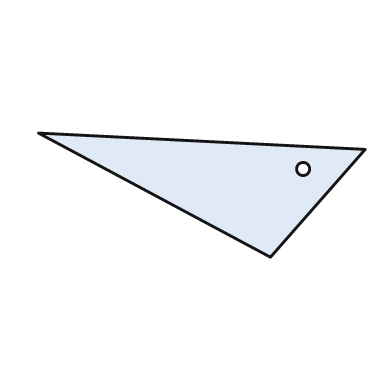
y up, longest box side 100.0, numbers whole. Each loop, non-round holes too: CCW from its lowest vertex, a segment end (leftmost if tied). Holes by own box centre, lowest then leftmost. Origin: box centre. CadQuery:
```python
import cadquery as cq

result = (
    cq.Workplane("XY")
    .moveTo(21.0, -19.0)
    .lineTo(50.0, 14.0)
    .lineTo(-50.0, 19.0)
    .close()
    .moveTo(31.0, 8.0)
    .circle(2.0)
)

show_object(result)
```